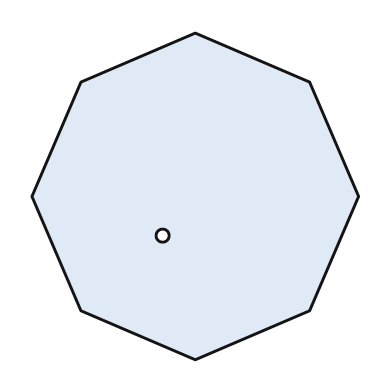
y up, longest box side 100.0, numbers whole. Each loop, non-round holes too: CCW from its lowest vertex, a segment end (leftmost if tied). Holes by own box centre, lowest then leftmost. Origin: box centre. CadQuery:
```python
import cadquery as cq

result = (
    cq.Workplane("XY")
    .moveTo(0.0, -50.0)
    .lineTo(35.0, -35.0)
    .lineTo(50.0, 0.0)
    .lineTo(35.0, 35.0)
    .lineTo(0.0, 50.0)
    .lineTo(-35.0, 35.0)
    .lineTo(-50.0, 0.0)
    .lineTo(-35.0, -35.0)
    .close()
    .moveTo(-10.0, -12.0)
    .circle(2.0)
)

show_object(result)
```